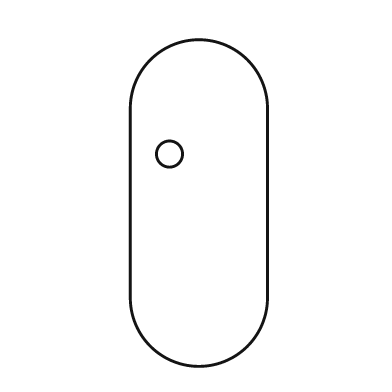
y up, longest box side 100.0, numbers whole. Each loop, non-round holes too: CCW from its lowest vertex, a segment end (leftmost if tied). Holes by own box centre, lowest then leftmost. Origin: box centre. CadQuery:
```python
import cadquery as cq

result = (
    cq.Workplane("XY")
    .moveTo(-21.0, -29.0)
    .threePointArc((0.0, -50.0), (21.0, -29.0))
    .lineTo(21.0, 29.0)
    .threePointArc((0.0, 50.0), (-21.0, 29.0))
    .close()
    .moveTo(-9.0, 15.0)
    .circle(4.0)
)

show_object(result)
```